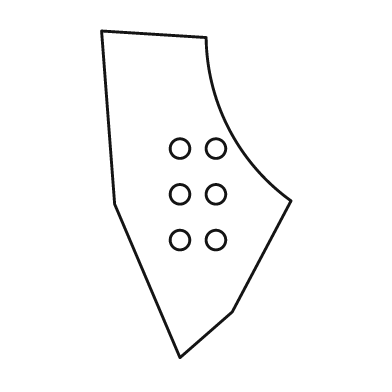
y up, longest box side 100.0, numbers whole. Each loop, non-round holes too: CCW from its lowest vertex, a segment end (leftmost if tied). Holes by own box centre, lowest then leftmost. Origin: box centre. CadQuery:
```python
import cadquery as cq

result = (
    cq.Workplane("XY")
    .moveTo(-5.0, -50.0)
    .lineTo(11.0, -36.0)
    .lineTo(29.0, -2.0)
    .threePointArc((10.0, 20.0), (3.0, 48.0))
    .lineTo(-29.0, 50.0)
    .lineTo(-25.0, -3.0)
    .close()
    .moveTo(-5.0, -14.0)
    .circle(3.0)
    .moveTo(6.0, -14.0)
    .circle(3.0)
    .moveTo(-5.0, 0.0)
    .circle(3.0)
    .moveTo(6.0, 0.0)
    .circle(3.0)
    .moveTo(-5.0, 14.0)
    .circle(3.0)
    .moveTo(6.0, 14.0)
    .circle(3.0)
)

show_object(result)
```